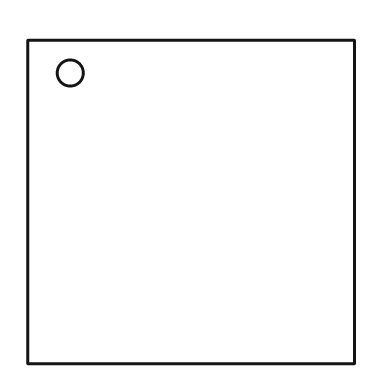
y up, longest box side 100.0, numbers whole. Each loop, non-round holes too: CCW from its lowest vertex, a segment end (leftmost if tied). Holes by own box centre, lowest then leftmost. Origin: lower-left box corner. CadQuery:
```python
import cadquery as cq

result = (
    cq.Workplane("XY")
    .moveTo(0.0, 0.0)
    .lineTo(100.0, 0.0)
    .lineTo(100.0, 99.0)
    .lineTo(0.0, 99.0)
    .close()
    .moveTo(13.0, 89.0)
    .circle(4.0)
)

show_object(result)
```